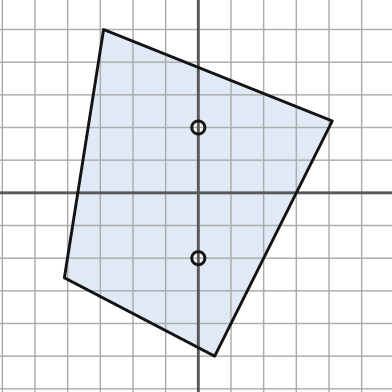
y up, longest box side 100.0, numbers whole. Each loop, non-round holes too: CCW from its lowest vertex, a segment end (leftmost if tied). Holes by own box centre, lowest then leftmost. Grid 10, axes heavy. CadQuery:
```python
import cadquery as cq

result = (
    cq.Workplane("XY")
    .moveTo(5.0, -50.0)
    .lineTo(41.0, 22.0)
    .lineTo(-29.0, 50.0)
    .lineTo(-41.0, -26.0)
    .close()
    .moveTo(0.0, -20.0)
    .circle(2.0)
    .moveTo(0.0, 20.0)
    .circle(2.0)
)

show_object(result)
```